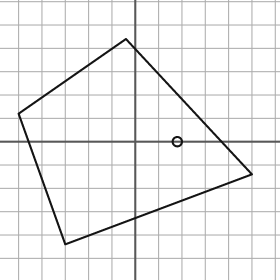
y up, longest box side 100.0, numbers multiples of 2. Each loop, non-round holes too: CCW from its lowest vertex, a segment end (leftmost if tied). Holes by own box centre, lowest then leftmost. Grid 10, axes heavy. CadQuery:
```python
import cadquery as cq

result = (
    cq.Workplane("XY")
    .moveTo(-30.0, -44.0)
    .lineTo(50.0, -14.0)
    .lineTo(-4.0, 44.0)
    .lineTo(-50.0, 12.0)
    .close()
    .moveTo(18.0, 0.0)
    .circle(2.0)
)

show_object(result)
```